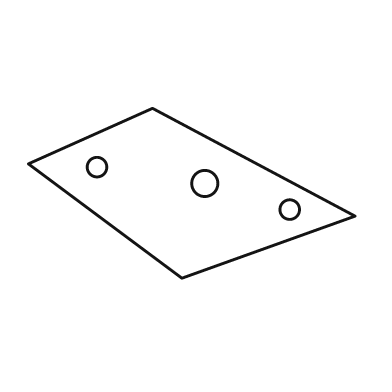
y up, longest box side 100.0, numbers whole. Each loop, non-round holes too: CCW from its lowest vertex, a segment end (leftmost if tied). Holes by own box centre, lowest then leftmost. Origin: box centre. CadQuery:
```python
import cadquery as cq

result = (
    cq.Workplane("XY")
    .moveTo(-3.0, -26.0)
    .lineTo(50.0, -7.0)
    .lineTo(-12.0, 26.0)
    .lineTo(-50.0, 9.0)
    .close()
    .moveTo(30.0, -5.0)
    .circle(3.0)
    .moveTo(4.0, 3.0)
    .circle(4.0)
    .moveTo(-29.0, 8.0)
    .circle(3.0)
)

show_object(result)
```